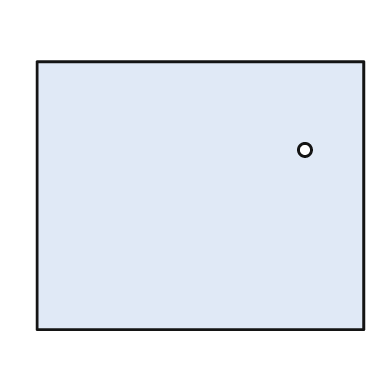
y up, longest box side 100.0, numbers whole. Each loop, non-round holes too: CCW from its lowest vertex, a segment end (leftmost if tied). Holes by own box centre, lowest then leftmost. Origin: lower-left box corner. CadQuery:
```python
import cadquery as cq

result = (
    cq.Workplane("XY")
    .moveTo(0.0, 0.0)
    .lineTo(100.0, 0.0)
    .lineTo(100.0, 82.0)
    .lineTo(0.0, 82.0)
    .close()
    .moveTo(82.0, 55.0)
    .circle(2.0)
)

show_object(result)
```